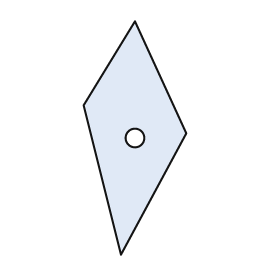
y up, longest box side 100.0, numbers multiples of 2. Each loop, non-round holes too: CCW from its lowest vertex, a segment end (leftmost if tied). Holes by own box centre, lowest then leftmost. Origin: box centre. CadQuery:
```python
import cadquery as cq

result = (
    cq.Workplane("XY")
    .moveTo(-6.0, -50.0)
    .lineTo(22.0, 2.0)
    .lineTo(0.0, 50.0)
    .lineTo(-22.0, 14.0)
    .close()
    .moveTo(0.0, 0.0)
    .circle(4.0)
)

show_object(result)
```